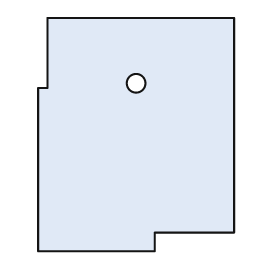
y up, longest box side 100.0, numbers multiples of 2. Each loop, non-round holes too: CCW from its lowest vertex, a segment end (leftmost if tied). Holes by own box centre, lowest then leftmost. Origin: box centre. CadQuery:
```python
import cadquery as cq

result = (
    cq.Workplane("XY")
    .moveTo(-42.0, -50.0)
    .lineTo(8.0, -50.0)
    .lineTo(8.0, -42.0)
    .lineTo(42.0, -42.0)
    .lineTo(42.0, 50.0)
    .lineTo(-38.0, 50.0)
    .lineTo(-38.0, 20.0)
    .lineTo(-42.0, 20.0)
    .close()
    .moveTo(0.0, 22.0)
    .circle(4.0)
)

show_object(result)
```